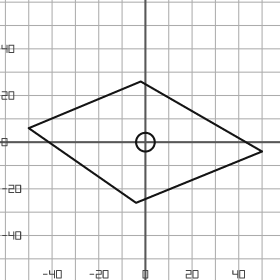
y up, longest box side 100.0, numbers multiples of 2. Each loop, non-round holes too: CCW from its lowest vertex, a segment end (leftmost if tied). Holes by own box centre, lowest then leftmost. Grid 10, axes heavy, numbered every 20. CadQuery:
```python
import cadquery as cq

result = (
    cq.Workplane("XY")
    .moveTo(-4.0, -26.0)
    .lineTo(50.0, -4.0)
    .lineTo(-2.0, 26.0)
    .lineTo(-50.0, 6.0)
    .close()
    .moveTo(0.0, 0.0)
    .circle(4.0)
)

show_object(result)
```